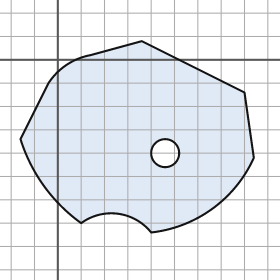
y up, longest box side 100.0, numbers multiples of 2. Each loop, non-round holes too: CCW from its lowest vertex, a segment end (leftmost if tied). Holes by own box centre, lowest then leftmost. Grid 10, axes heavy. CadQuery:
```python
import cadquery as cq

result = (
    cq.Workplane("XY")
    .moveTo(40.0, -74.0)
    .threePointArc((66.0, -64.0), (84.0, -42.0))
    .lineTo(80.0, -14.0)
    .lineTo(36.0, 8.0)
    .lineTo(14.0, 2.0)
    .threePointArc((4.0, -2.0), (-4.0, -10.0))
    .lineTo(-16.0, -34.0)
    .threePointArc((-6.0, -54.0), (10.0, -70.0))
    .threePointArc((26.0, -66.0), (40.0, -74.0))
    .close()
    .moveTo(46.0, -40.0)
    .circle(6.0)
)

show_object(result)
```